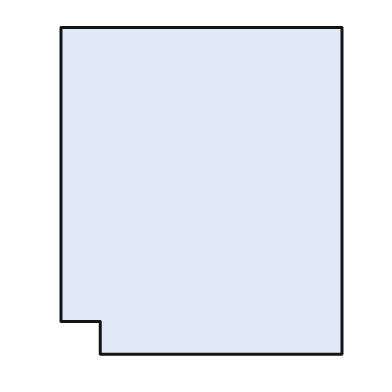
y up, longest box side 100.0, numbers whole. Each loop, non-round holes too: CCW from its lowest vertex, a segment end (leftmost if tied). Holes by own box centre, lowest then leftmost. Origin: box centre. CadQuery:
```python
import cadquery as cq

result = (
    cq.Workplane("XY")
    .moveTo(-31.0, -50.0)
    .lineTo(43.0, -50.0)
    .lineTo(43.0, 50.0)
    .lineTo(-43.0, 50.0)
    .lineTo(-43.0, -40.0)
    .lineTo(-31.0, -40.0)
    .close()
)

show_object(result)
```